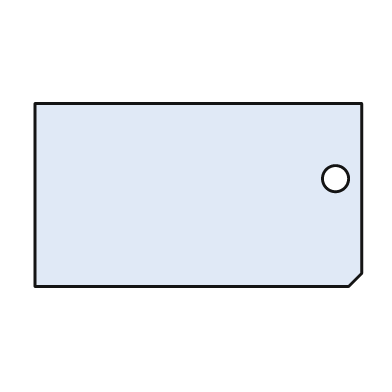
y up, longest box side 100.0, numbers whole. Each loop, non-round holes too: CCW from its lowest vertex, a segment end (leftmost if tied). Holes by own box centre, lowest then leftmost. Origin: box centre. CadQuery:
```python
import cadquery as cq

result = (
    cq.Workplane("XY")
    .moveTo(-50.0, -28.0)
    .lineTo(46.0, -28.0)
    .lineTo(50.0, -24.0)
    .lineTo(50.0, 28.0)
    .lineTo(-50.0, 28.0)
    .close()
    .moveTo(42.0, 5.0)
    .circle(4.0)
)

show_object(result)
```